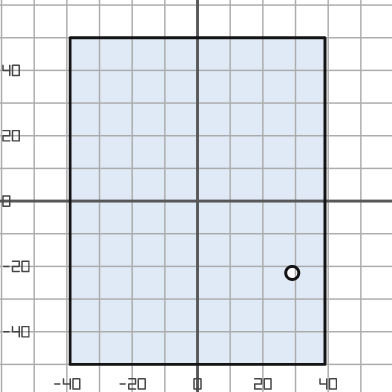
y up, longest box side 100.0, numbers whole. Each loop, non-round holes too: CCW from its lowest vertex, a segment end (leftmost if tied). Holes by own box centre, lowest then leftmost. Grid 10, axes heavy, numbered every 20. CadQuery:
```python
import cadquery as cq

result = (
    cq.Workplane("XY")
    .moveTo(-39.0, -50.0)
    .lineTo(39.0, -50.0)
    .lineTo(39.0, 50.0)
    .lineTo(-39.0, 50.0)
    .close()
    .moveTo(29.0, -22.0)
    .circle(2.0)
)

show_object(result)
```